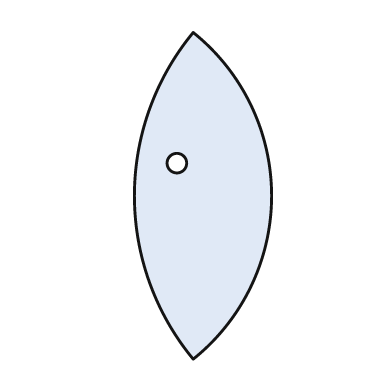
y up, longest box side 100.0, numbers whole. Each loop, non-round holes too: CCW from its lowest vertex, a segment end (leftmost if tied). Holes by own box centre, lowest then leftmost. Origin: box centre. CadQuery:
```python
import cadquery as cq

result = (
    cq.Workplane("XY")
    .moveTo(-3.0, -50.0)
    .threePointArc((21.0, 0.0), (-3.0, 50.0))
    .threePointArc((-21.0, 0.0), (-3.0, -50.0))
    .close()
    .moveTo(-8.0, 10.0)
    .circle(3.0)
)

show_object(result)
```